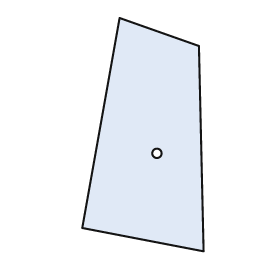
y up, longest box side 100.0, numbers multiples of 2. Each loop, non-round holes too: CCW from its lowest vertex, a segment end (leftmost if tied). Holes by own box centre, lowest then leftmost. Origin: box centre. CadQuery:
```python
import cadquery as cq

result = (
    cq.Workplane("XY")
    .moveTo(26.0, -50.0)
    .lineTo(24.0, 38.0)
    .lineTo(-10.0, 50.0)
    .lineTo(-26.0, -40.0)
    .close()
    .moveTo(6.0, -8.0)
    .circle(2.0)
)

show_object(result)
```